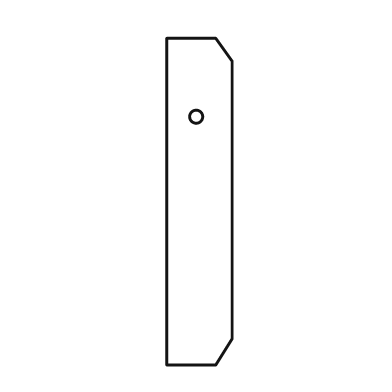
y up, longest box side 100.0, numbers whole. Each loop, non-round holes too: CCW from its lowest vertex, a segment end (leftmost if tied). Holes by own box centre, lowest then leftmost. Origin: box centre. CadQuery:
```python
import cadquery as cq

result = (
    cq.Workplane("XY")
    .moveTo(-10.0, -50.0)
    .lineTo(5.0, -50.0)
    .lineTo(10.0, -42.0)
    .lineTo(10.0, 43.0)
    .lineTo(5.0, 50.0)
    .lineTo(-10.0, 50.0)
    .close()
    .moveTo(-1.0, 26.0)
    .circle(2.0)
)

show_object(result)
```